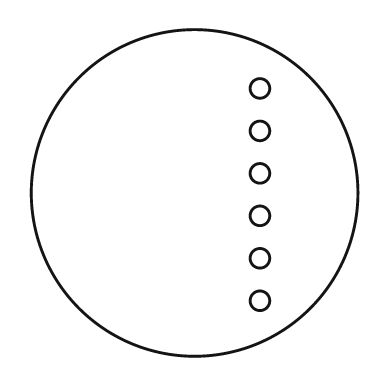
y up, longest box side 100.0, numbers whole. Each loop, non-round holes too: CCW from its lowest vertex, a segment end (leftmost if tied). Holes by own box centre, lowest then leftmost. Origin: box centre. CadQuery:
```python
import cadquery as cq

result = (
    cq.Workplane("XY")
    .moveTo(0.0, 0.0)
    .circle(50.0)
    .moveTo(20.0, -33.0)
    .circle(3.0)
    .moveTo(20.0, -20.0)
    .circle(3.0)
    .moveTo(20.0, -7.0)
    .circle(3.0)
    .moveTo(20.0, 6.0)
    .circle(3.0)
    .moveTo(20.0, 19.0)
    .circle(3.0)
    .moveTo(20.0, 32.0)
    .circle(3.0)
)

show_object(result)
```